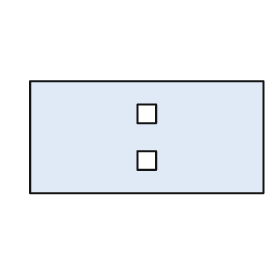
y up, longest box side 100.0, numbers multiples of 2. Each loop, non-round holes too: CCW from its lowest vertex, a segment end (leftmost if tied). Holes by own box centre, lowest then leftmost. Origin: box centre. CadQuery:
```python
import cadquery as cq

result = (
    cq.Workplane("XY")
    .moveTo(-50.0, -24.0)
    .lineTo(50.0, -24.0)
    .lineTo(50.0, 24.0)
    .lineTo(-50.0, 24.0)
    .close()
    .moveTo(-4.0, -14.0)
    .lineTo(4.0, -14.0)
    .lineTo(4.0, -6.0)
    .lineTo(-4.0, -6.0)
    .close()
    .moveTo(-4.0, 6.0)
    .lineTo(4.0, 6.0)
    .lineTo(4.0, 14.0)
    .lineTo(-4.0, 14.0)
    .close()
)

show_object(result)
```